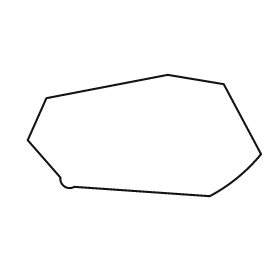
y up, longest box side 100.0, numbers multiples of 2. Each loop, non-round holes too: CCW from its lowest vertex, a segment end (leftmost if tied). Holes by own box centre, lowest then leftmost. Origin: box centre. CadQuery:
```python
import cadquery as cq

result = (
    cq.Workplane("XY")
    .moveTo(28.0, -26.0)
    .threePointArc((40.0, -18.0), (50.0, -8.0))
    .lineTo(34.0, 22.0)
    .lineTo(10.0, 26.0)
    .lineTo(-42.0, 16.0)
    .lineTo(-50.0, -2.0)
    .lineTo(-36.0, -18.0)
    .threePointArc((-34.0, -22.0), (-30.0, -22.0))
    .close()
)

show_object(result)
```